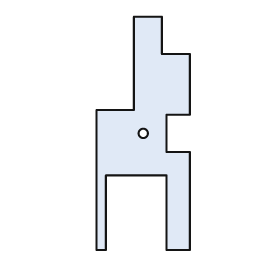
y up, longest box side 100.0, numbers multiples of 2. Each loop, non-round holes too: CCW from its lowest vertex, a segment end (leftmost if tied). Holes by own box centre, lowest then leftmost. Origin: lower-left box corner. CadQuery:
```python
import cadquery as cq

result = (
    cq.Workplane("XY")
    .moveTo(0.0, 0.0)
    .lineTo(4.0, 0.0)
    .lineTo(4.0, 32.0)
    .lineTo(30.0, 32.0)
    .lineTo(30.0, 0.0)
    .lineTo(40.0, 0.0)
    .lineTo(40.0, 42.0)
    .lineTo(30.0, 42.0)
    .lineTo(30.0, 58.0)
    .lineTo(40.0, 58.0)
    .lineTo(40.0, 84.0)
    .lineTo(28.0, 84.0)
    .lineTo(28.0, 100.0)
    .lineTo(16.0, 100.0)
    .lineTo(16.0, 60.0)
    .lineTo(0.0, 60.0)
    .close()
    .moveTo(20.0, 50.0)
    .circle(2.0)
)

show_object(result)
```